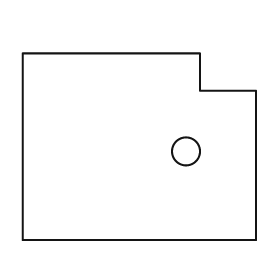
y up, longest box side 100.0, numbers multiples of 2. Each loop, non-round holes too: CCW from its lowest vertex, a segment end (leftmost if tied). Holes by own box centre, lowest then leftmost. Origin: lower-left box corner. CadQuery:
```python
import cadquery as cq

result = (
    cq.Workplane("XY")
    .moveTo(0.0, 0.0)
    .lineTo(100.0, 0.0)
    .lineTo(100.0, 64.0)
    .lineTo(76.0, 64.0)
    .lineTo(76.0, 80.0)
    .lineTo(0.0, 80.0)
    .close()
    .moveTo(70.0, 38.0)
    .circle(6.0)
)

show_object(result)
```